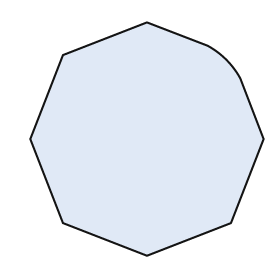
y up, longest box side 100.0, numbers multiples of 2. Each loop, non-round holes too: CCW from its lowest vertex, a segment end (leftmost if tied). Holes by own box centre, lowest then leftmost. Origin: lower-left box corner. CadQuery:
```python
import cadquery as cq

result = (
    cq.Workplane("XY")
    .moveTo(50.0, 0.0)
    .lineTo(86.0, 14.0)
    .lineTo(100.0, 50.0)
    .lineTo(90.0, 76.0)
    .threePointArc((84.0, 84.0), (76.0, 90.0))
    .lineTo(50.0, 100.0)
    .lineTo(14.0, 86.0)
    .lineTo(0.0, 50.0)
    .lineTo(14.0, 14.0)
    .close()
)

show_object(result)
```